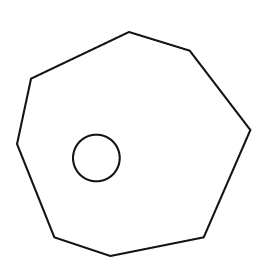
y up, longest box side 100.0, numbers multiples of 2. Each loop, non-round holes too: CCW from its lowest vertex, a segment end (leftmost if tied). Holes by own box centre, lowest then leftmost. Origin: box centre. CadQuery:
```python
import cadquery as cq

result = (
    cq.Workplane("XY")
    .moveTo(-10.0, -48.0)
    .lineTo(30.0, -40.0)
    .lineTo(50.0, 6.0)
    .lineTo(24.0, 40.0)
    .lineTo(-2.0, 48.0)
    .lineTo(-44.0, 28.0)
    .lineTo(-50.0, 0.0)
    .lineTo(-34.0, -40.0)
    .close()
    .moveTo(-16.0, -6.0)
    .circle(10.0)
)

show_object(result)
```